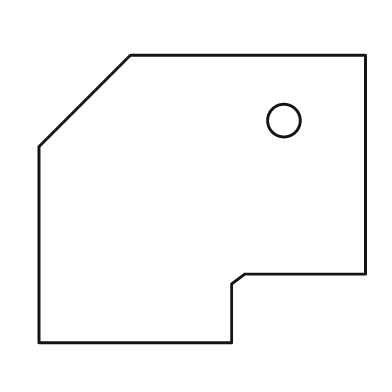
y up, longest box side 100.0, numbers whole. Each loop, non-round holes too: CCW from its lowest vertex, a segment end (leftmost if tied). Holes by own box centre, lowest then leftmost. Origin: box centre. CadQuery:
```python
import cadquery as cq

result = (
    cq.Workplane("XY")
    .moveTo(-50.0, -44.0)
    .lineTo(9.0, -44.0)
    .lineTo(9.0, -26.0)
    .lineTo(13.0, -23.0)
    .lineTo(50.0, -23.0)
    .lineTo(50.0, 44.0)
    .lineTo(-22.0, 44.0)
    .lineTo(-50.0, 16.0)
    .close()
    .moveTo(25.0, 24.0)
    .circle(5.0)
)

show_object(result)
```